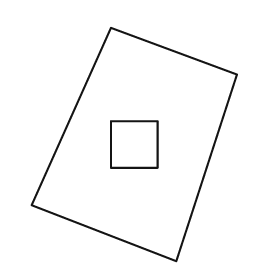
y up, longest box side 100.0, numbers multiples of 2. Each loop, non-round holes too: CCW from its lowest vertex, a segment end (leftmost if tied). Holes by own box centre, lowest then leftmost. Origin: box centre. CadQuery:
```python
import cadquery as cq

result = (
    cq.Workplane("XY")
    .moveTo(18.0, -50.0)
    .lineTo(44.0, 30.0)
    .lineTo(-10.0, 50.0)
    .lineTo(-44.0, -26.0)
    .close()
    .moveTo(-10.0, -10.0)
    .lineTo(10.0, -10.0)
    .lineTo(10.0, 10.0)
    .lineTo(-10.0, 10.0)
    .close()
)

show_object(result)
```